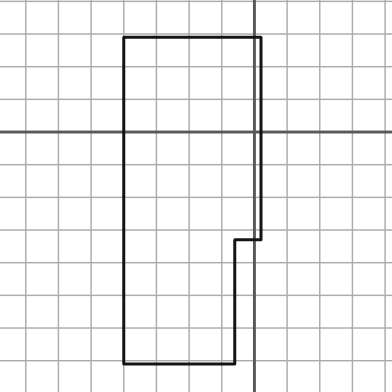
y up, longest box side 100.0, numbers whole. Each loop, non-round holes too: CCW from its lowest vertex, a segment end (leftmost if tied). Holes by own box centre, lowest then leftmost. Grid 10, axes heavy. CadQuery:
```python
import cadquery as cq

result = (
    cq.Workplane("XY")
    .moveTo(-40.0, -71.0)
    .lineTo(-6.0, -71.0)
    .lineTo(-6.0, -33.0)
    .lineTo(2.0, -33.0)
    .lineTo(2.0, 29.0)
    .lineTo(-40.0, 29.0)
    .close()
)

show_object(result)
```